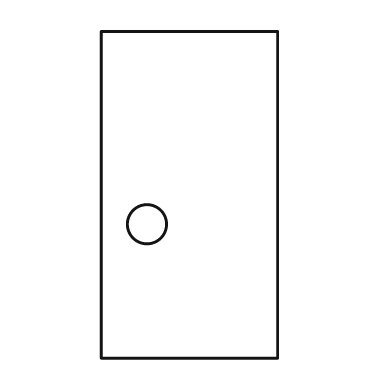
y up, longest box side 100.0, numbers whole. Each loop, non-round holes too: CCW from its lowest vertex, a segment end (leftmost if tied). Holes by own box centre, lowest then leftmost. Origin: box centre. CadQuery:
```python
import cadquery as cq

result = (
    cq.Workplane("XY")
    .moveTo(-27.0, -50.0)
    .lineTo(27.0, -50.0)
    .lineTo(27.0, 50.0)
    .lineTo(-27.0, 50.0)
    .close()
    .moveTo(-13.0, -9.0)
    .circle(6.0)
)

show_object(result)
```